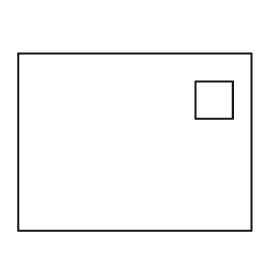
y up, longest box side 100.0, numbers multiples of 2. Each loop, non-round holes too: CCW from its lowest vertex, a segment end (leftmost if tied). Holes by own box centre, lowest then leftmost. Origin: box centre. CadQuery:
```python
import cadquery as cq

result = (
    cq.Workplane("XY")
    .moveTo(-50.0, -38.0)
    .lineTo(50.0, -38.0)
    .lineTo(50.0, 38.0)
    .lineTo(-50.0, 38.0)
    .close()
    .moveTo(26.0, 10.0)
    .lineTo(42.0, 10.0)
    .lineTo(42.0, 26.0)
    .lineTo(26.0, 26.0)
    .close()
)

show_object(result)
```